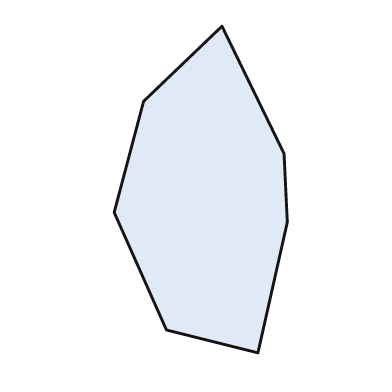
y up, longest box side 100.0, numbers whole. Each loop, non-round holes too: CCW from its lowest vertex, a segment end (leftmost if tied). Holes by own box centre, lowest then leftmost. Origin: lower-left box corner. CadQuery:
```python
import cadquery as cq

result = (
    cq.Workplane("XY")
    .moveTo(44.0, 0.0)
    .lineTo(53.0, 40.0)
    .lineTo(52.0, 61.0)
    .lineTo(33.0, 100.0)
    .lineTo(9.0, 77.0)
    .lineTo(0.0, 43.0)
    .lineTo(16.0, 7.0)
    .close()
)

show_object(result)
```